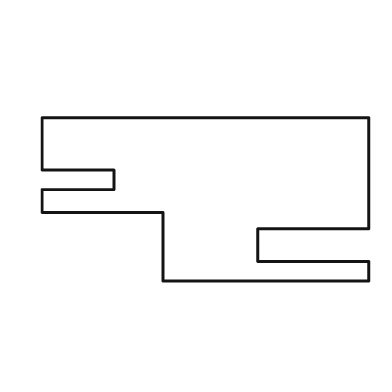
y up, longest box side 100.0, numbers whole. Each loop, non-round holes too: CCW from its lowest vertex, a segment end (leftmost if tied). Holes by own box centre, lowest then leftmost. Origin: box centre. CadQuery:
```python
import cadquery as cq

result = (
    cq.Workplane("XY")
    .moveTo(-13.0, -25.0)
    .lineTo(50.0, -25.0)
    .lineTo(50.0, -19.0)
    .lineTo(16.0, -19.0)
    .lineTo(16.0, -9.0)
    .lineTo(50.0, -9.0)
    .lineTo(50.0, 25.0)
    .lineTo(-50.0, 25.0)
    .lineTo(-50.0, 9.0)
    .lineTo(-28.0, 9.0)
    .lineTo(-28.0, 3.0)
    .lineTo(-50.0, 3.0)
    .lineTo(-50.0, -4.0)
    .lineTo(-13.0, -4.0)
    .close()
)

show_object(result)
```